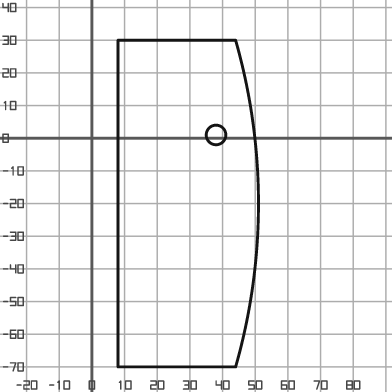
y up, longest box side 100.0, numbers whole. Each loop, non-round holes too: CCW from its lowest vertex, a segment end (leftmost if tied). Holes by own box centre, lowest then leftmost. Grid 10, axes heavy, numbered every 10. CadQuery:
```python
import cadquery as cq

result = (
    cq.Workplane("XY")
    .moveTo(8.0, -70.0)
    .lineTo(44.0, -70.0)
    .threePointArc((51.0, -20.0), (44.0, 30.0))
    .lineTo(8.0, 30.0)
    .close()
    .moveTo(38.0, 1.0)
    .circle(3.0)
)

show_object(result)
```